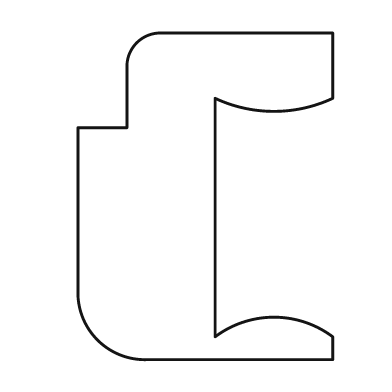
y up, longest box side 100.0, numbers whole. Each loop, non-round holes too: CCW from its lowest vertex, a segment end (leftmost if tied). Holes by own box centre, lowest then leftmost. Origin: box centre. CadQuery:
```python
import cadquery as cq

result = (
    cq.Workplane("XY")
    .moveTo(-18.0, -50.0)
    .lineTo(39.0, -50.0)
    .lineTo(39.0, -43.0)
    .threePointArc((21.0, -37.0), (3.0, -43.0))
    .lineTo(3.0, 30.0)
    .threePointArc((21.0, 26.0), (39.0, 30.0))
    .lineTo(39.0, 50.0)
    .lineTo(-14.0, 50.0)
    .threePointArc((-21.0, 47.0), (-24.0, 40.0))
    .lineTo(-24.0, 21.0)
    .lineTo(-39.0, 21.0)
    .lineTo(-39.0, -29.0)
    .threePointArc((-33.0, -44.0), (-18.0, -50.0))
    .close()
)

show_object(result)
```